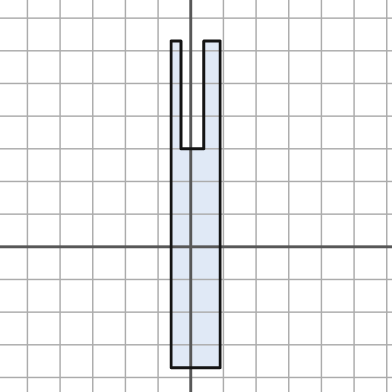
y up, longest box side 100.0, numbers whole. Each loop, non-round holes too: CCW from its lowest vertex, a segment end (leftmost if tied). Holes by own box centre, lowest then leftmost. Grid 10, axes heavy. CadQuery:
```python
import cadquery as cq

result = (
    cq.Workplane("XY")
    .moveTo(-6.0, -37.0)
    .lineTo(9.0, -37.0)
    .lineTo(9.0, 63.0)
    .lineTo(4.0, 63.0)
    .lineTo(4.0, 30.0)
    .lineTo(-3.0, 30.0)
    .lineTo(-3.0, 63.0)
    .lineTo(-6.0, 63.0)
    .close()
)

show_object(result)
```